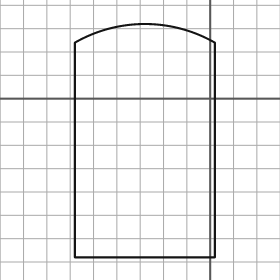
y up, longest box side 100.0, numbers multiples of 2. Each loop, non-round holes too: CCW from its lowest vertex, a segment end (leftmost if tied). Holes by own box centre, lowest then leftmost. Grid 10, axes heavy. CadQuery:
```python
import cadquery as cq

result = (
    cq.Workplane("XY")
    .moveTo(-58.0, -68.0)
    .lineTo(2.0, -68.0)
    .lineTo(2.0, 24.0)
    .threePointArc((-28.0, 32.0), (-58.0, 24.0))
    .close()
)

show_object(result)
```